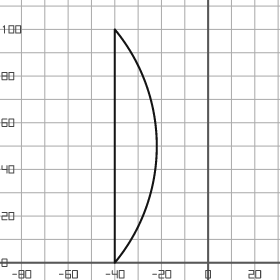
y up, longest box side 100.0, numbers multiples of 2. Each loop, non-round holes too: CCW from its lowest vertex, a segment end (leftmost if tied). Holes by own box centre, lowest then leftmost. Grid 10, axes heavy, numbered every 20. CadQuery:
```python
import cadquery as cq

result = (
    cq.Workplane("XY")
    .moveTo(-40.0, 0.0)
    .threePointArc((-22.0, 50.0), (-40.0, 100.0))
    .close()
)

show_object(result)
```